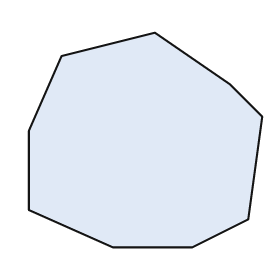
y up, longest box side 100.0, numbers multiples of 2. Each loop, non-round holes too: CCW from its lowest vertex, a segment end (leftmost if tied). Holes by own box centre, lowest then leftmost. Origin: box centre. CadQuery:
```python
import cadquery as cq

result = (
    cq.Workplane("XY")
    .moveTo(-14.0, -46.0)
    .lineTo(20.0, -46.0)
    .lineTo(44.0, -34.0)
    .lineTo(50.0, 10.0)
    .lineTo(36.0, 24.0)
    .lineTo(4.0, 46.0)
    .lineTo(-36.0, 36.0)
    .lineTo(-50.0, 4.0)
    .lineTo(-50.0, -30.0)
    .close()
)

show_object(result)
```